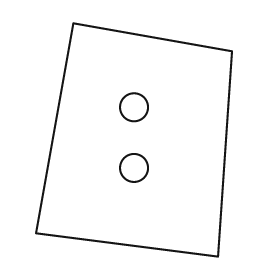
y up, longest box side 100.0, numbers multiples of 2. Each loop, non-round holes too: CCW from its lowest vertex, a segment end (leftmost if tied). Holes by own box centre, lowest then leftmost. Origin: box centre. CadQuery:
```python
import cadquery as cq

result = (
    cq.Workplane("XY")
    .moveTo(36.0, -50.0)
    .lineTo(42.0, 38.0)
    .lineTo(-26.0, 50.0)
    .lineTo(-42.0, -40.0)
    .close()
    .moveTo(0.0, -12.0)
    .circle(6.0)
    .moveTo(0.0, 14.0)
    .circle(6.0)
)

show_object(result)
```